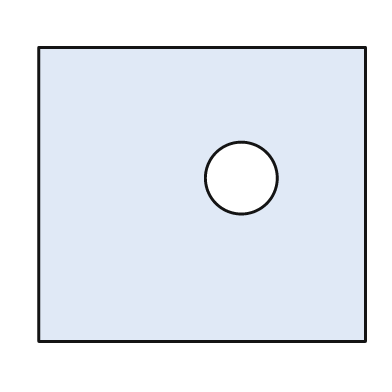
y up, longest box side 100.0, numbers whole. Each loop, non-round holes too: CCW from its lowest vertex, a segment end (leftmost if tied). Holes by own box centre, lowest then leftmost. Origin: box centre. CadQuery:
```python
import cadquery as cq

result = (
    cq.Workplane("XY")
    .moveTo(-50.0, -45.0)
    .lineTo(50.0, -45.0)
    .lineTo(50.0, 45.0)
    .lineTo(-50.0, 45.0)
    .close()
    .moveTo(12.0, 5.0)
    .circle(11.0)
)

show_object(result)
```